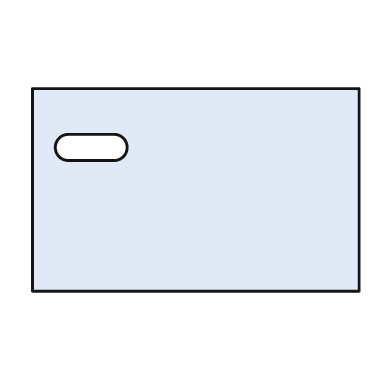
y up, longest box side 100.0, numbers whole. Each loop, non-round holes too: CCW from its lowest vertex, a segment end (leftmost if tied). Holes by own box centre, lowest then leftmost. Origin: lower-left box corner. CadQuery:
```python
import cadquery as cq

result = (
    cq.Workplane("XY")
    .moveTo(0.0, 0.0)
    .lineTo(100.0, 0.0)
    .lineTo(100.0, 62.0)
    .lineTo(0.0, 62.0)
    .close()
    .moveTo(11.0, 40.0)
    .lineTo(25.0, 40.0)
    .threePointArc((29.0, 44.0), (25.0, 48.0))
    .lineTo(11.0, 48.0)
    .threePointArc((7.0, 44.0), (11.0, 40.0))
    .close()
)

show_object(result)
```